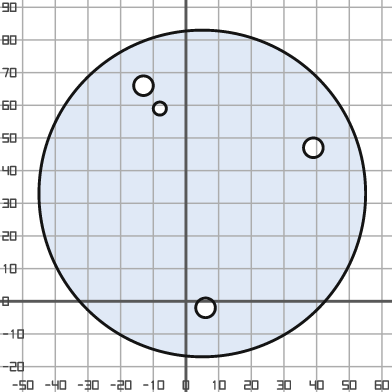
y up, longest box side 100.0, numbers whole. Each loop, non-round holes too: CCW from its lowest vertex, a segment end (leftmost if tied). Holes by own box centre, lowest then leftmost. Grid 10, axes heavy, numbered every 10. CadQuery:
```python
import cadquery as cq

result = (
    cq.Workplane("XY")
    .moveTo(5.0, 33.0)
    .circle(50.0)
    .moveTo(6.0, -2.0)
    .circle(3.0)
    .moveTo(39.0, 47.0)
    .circle(3.0)
    .moveTo(-8.0, 59.0)
    .circle(2.0)
    .moveTo(-13.0, 66.0)
    .circle(3.0)
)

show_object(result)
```